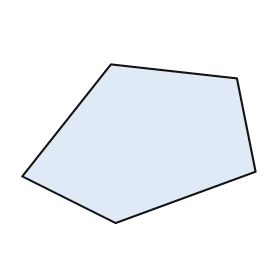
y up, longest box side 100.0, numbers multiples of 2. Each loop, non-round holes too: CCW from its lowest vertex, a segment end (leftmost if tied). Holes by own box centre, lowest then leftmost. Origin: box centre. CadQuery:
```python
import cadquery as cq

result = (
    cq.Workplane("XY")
    .moveTo(-10.0, -34.0)
    .lineTo(50.0, -12.0)
    .lineTo(42.0, 28.0)
    .lineTo(-12.0, 34.0)
    .lineTo(-50.0, -14.0)
    .close()
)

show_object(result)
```